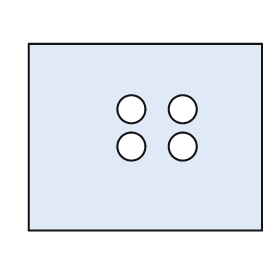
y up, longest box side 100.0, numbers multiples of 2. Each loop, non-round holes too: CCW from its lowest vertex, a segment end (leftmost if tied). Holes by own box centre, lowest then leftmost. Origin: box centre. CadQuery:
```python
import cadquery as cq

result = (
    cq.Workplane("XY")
    .moveTo(-50.0, -40.0)
    .lineTo(50.0, -40.0)
    .lineTo(50.0, 40.0)
    .lineTo(-50.0, 40.0)
    .close()
    .moveTo(-6.0, -4.0)
    .circle(6.0)
    .moveTo(16.0, -4.0)
    .circle(6.0)
    .moveTo(-6.0, 12.0)
    .circle(6.0)
    .moveTo(16.0, 12.0)
    .circle(6.0)
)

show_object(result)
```